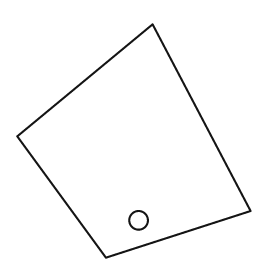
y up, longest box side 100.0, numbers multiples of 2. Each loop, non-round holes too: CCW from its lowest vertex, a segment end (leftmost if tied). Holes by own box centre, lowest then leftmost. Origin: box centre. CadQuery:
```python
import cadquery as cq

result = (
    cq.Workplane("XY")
    .moveTo(-12.0, -50.0)
    .lineTo(50.0, -30.0)
    .lineTo(8.0, 50.0)
    .lineTo(-50.0, 2.0)
    .close()
    .moveTo(2.0, -34.0)
    .circle(4.0)
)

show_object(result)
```